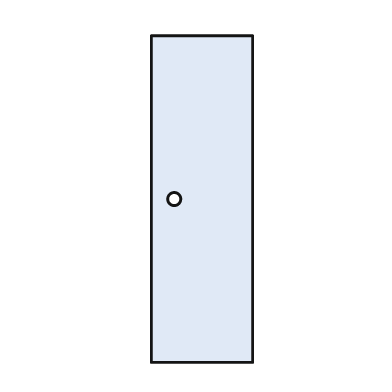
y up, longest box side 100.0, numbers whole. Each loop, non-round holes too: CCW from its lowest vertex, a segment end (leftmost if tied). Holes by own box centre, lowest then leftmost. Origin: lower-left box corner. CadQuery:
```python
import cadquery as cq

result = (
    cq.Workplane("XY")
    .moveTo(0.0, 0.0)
    .lineTo(31.0, 0.0)
    .lineTo(31.0, 100.0)
    .lineTo(0.0, 100.0)
    .close()
    .moveTo(7.0, 50.0)
    .circle(2.0)
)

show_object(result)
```